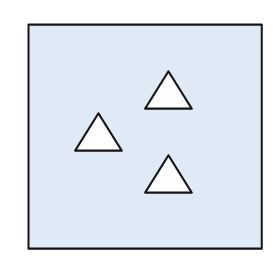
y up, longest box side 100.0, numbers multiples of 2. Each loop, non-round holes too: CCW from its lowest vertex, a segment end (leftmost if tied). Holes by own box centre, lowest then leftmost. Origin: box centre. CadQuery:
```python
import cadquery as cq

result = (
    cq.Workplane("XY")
    .moveTo(-50.0, -48.0)
    .lineTo(50.0, -48.0)
    .lineTo(50.0, 48.0)
    .lineTo(-50.0, 48.0)
    .close()
    .moveTo(0.0, -24.0)
    .lineTo(20.0, -24.0)
    .lineTo(10.0, -8.0)
    .close()
    .moveTo(-30.0, -6.0)
    .lineTo(-10.0, -6.0)
    .lineTo(-20.0, 10.0)
    .close()
    .moveTo(0.0, 12.0)
    .lineTo(20.0, 12.0)
    .lineTo(10.0, 28.0)
    .close()
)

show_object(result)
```